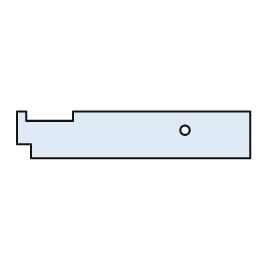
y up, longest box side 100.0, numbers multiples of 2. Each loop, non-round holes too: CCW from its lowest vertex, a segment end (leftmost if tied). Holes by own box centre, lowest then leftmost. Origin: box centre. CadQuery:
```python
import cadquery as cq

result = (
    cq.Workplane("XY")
    .moveTo(-44.0, -10.0)
    .lineTo(50.0, -10.0)
    .lineTo(50.0, 10.0)
    .lineTo(-26.0, 10.0)
    .lineTo(-26.0, 6.0)
    .lineTo(-46.0, 6.0)
    .lineTo(-46.0, 10.0)
    .lineTo(-50.0, 10.0)
    .lineTo(-50.0, -4.0)
    .lineTo(-44.0, -4.0)
    .close()
    .moveTo(22.0, 2.0)
    .circle(2.0)
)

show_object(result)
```